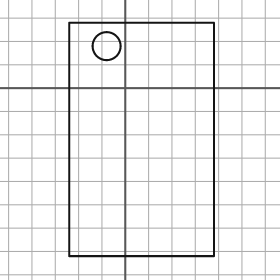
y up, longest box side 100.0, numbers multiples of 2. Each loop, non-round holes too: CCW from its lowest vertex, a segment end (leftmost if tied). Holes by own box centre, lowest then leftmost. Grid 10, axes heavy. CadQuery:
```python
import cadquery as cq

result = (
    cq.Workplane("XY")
    .moveTo(-24.0, -72.0)
    .lineTo(38.0, -72.0)
    .lineTo(38.0, 28.0)
    .lineTo(-24.0, 28.0)
    .close()
    .moveTo(-8.0, 18.0)
    .circle(6.0)
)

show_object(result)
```